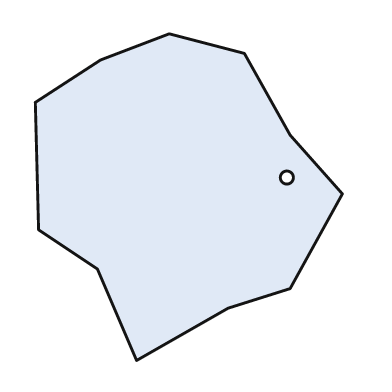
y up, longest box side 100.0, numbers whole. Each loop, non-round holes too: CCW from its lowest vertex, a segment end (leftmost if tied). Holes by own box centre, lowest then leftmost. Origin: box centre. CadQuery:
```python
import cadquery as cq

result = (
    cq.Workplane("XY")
    .moveTo(-16.0, -50.0)
    .lineTo(12.0, -34.0)
    .lineTo(31.0, -28.0)
    .lineTo(47.0, 1.0)
    .lineTo(31.0, 19.0)
    .lineTo(17.0, 44.0)
    .lineTo(-6.0, 50.0)
    .lineTo(-27.0, 42.0)
    .lineTo(-47.0, 29.0)
    .lineTo(-46.0, -10.0)
    .lineTo(-28.0, -22.0)
    .close()
    .moveTo(30.0, 6.0)
    .circle(2.0)
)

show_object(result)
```